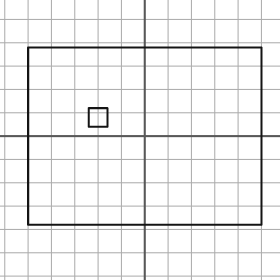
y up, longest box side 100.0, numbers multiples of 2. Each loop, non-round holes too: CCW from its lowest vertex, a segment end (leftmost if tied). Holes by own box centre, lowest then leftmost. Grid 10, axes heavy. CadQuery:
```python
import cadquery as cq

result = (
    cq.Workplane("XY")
    .moveTo(-50.0, -38.0)
    .lineTo(50.0, -38.0)
    .lineTo(50.0, 38.0)
    .lineTo(-50.0, 38.0)
    .close()
    .moveTo(-24.0, 4.0)
    .lineTo(-16.0, 4.0)
    .lineTo(-16.0, 12.0)
    .lineTo(-24.0, 12.0)
    .close()
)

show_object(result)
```